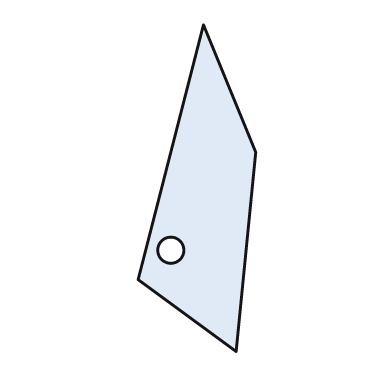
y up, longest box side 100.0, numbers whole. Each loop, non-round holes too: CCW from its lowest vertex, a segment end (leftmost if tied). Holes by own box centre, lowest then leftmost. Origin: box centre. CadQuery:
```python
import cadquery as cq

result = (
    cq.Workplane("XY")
    .moveTo(12.0, -50.0)
    .lineTo(18.0, 11.0)
    .lineTo(2.0, 50.0)
    .lineTo(-18.0, -28.0)
    .close()
    .moveTo(-8.0, -19.0)
    .circle(4.0)
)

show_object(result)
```